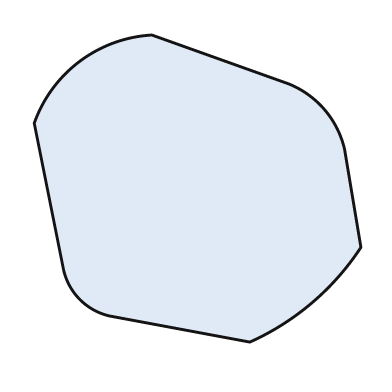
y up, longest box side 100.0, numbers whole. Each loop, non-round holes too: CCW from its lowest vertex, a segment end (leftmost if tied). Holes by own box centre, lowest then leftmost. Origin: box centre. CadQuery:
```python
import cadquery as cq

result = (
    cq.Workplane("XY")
    .moveTo(16.0, -47.0)
    .threePointArc((35.0, -35.0), (50.0, -18.0))
    .lineTo(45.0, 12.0)
    .threePointArc((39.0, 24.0), (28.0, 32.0))
    .lineTo(-14.0, 47.0)
    .threePointArc((-36.0, 39.0), (-50.0, 20.0))
    .lineTo(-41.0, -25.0)
    .threePointArc((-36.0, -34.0), (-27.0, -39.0))
    .close()
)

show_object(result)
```